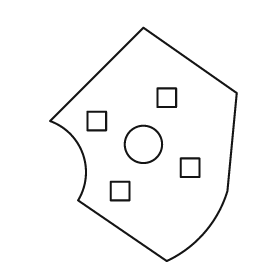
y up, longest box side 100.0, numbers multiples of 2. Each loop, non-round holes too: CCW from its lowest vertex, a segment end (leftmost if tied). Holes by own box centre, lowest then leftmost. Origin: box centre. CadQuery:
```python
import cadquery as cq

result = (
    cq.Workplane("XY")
    .moveTo(10.0, -50.0)
    .threePointArc((26.0, -38.0), (36.0, -20.0))
    .lineTo(40.0, 22.0)
    .lineTo(0.0, 50.0)
    .lineTo(-40.0, 10.0)
    .threePointArc((-26.0, -4.0), (-28.0, -24.0))
    .close()
    .moveTo(-14.0, -24.0)
    .lineTo(-6.0, -24.0)
    .lineTo(-6.0, -16.0)
    .lineTo(-14.0, -16.0)
    .close()
    .moveTo(16.0, -14.0)
    .lineTo(24.0, -14.0)
    .lineTo(24.0, -6.0)
    .lineTo(16.0, -6.0)
    .close()
    .moveTo(0.0, 0.0)
    .circle(8.0)
    .moveTo(-24.0, 6.0)
    .lineTo(-16.0, 6.0)
    .lineTo(-16.0, 14.0)
    .lineTo(-24.0, 14.0)
    .close()
    .moveTo(6.0, 16.0)
    .lineTo(14.0, 16.0)
    .lineTo(14.0, 24.0)
    .lineTo(6.0, 24.0)
    .close()
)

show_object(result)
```